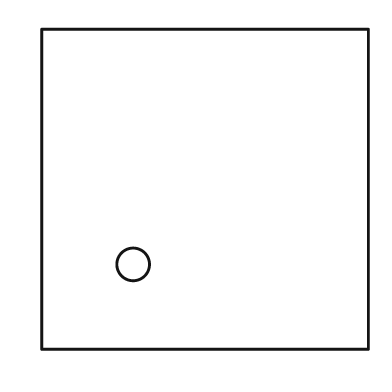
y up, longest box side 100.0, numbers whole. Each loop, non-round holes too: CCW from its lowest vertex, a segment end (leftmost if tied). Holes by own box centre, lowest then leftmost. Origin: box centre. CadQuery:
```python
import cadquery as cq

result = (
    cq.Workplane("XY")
    .moveTo(-50.0, -49.0)
    .lineTo(50.0, -49.0)
    .lineTo(50.0, 49.0)
    .lineTo(-50.0, 49.0)
    .close()
    .moveTo(-22.0, -23.0)
    .circle(5.0)
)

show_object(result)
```